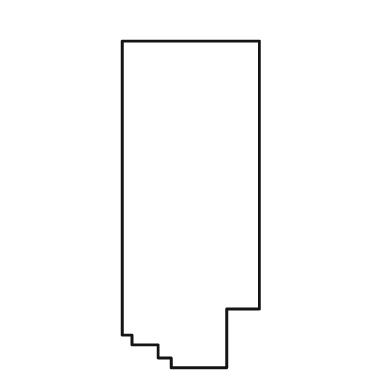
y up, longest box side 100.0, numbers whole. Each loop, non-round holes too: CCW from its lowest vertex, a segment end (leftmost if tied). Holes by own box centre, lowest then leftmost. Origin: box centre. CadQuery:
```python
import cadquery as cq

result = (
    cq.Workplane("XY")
    .moveTo(-6.0, -50.0)
    .lineTo(11.0, -50.0)
    .lineTo(11.0, -32.0)
    .lineTo(21.0, -32.0)
    .lineTo(21.0, 50.0)
    .lineTo(-21.0, 50.0)
    .lineTo(-21.0, -40.0)
    .lineTo(-18.0, -40.0)
    .lineTo(-18.0, -43.0)
    .lineTo(-10.0, -43.0)
    .lineTo(-10.0, -47.0)
    .lineTo(-6.0, -47.0)
    .close()
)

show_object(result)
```